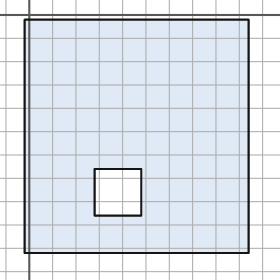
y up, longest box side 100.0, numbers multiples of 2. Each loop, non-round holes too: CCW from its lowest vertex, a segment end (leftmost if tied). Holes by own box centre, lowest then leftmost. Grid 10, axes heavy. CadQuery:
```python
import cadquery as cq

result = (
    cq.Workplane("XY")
    .moveTo(-2.0, -102.0)
    .lineTo(94.0, -102.0)
    .lineTo(94.0, -2.0)
    .lineTo(-2.0, -2.0)
    .close()
    .moveTo(28.0, -86.0)
    .lineTo(48.0, -86.0)
    .lineTo(48.0, -66.0)
    .lineTo(28.0, -66.0)
    .close()
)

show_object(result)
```